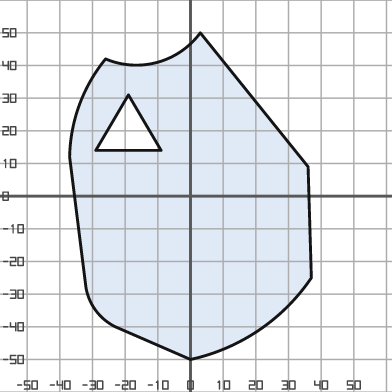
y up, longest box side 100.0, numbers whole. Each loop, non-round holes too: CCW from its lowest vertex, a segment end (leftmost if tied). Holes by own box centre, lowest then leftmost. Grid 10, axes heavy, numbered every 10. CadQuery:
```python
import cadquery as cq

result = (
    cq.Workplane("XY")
    .moveTo(0.0, -50.0)
    .threePointArc((21.0, -41.0), (37.0, -25.0))
    .lineTo(36.0, 9.0)
    .lineTo(3.0, 50.0)
    .threePointArc((-10.0, 41.0), (-26.0, 42.0))
    .threePointArc((-34.0, 28.0), (-37.0, 12.0))
    .lineTo(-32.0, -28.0)
    .threePointArc((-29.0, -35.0), (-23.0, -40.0))
    .close()
    .moveTo(-29.0, 14.0)
    .lineTo(-9.0, 14.0)
    .lineTo(-19.0, 31.0)
    .close()
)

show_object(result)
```